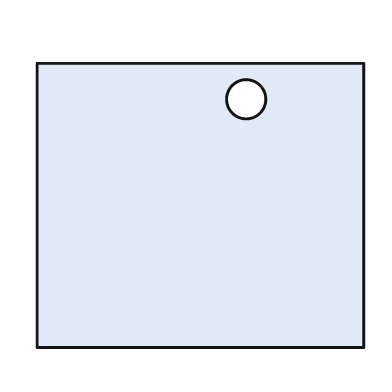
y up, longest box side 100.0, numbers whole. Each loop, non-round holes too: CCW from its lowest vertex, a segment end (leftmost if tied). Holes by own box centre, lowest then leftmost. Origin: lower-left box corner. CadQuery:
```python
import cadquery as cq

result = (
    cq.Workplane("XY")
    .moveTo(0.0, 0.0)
    .lineTo(100.0, 0.0)
    .lineTo(100.0, 87.0)
    .lineTo(0.0, 87.0)
    .close()
    .moveTo(64.0, 76.0)
    .circle(6.0)
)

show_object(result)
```